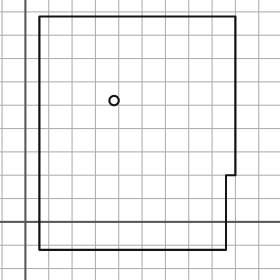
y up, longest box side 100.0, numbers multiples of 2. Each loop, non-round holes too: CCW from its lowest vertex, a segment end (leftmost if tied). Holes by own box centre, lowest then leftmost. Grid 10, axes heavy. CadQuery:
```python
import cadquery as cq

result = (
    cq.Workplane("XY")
    .moveTo(6.0, -12.0)
    .lineTo(86.0, -12.0)
    .lineTo(86.0, 20.0)
    .lineTo(90.0, 20.0)
    .lineTo(90.0, 88.0)
    .lineTo(6.0, 88.0)
    .close()
    .moveTo(38.0, 52.0)
    .circle(2.0)
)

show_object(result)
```